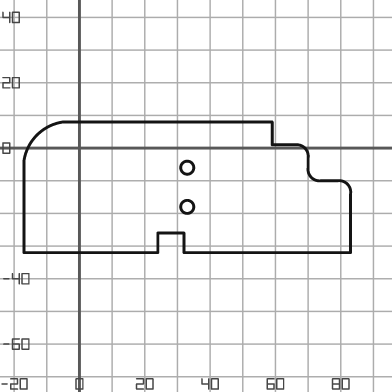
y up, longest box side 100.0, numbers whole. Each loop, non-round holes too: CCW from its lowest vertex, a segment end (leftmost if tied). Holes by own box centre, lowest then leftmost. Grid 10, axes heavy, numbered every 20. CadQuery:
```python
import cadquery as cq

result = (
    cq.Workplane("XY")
    .moveTo(-17.0, -32.0)
    .lineTo(24.0, -32.0)
    .lineTo(24.0, -26.0)
    .lineTo(32.0, -26.0)
    .lineTo(32.0, -32.0)
    .lineTo(83.0, -32.0)
    .lineTo(83.0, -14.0)
    .threePointArc((82.0, -11.0), (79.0, -10.0))
    .lineTo(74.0, -10.0)
    .threePointArc((71.0, -9.0), (70.0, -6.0))
    .lineTo(70.0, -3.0)
    .threePointArc((69.0, 0.0), (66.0, 1.0))
    .lineTo(59.0, 1.0)
    .lineTo(59.0, 8.0)
    .lineTo(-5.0, 8.0)
    .threePointArc((-13.0, 4.0), (-17.0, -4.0))
    .close()
    .moveTo(33.0, -18.0)
    .circle(2.0)
    .moveTo(33.0, -6.0)
    .circle(2.0)
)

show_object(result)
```